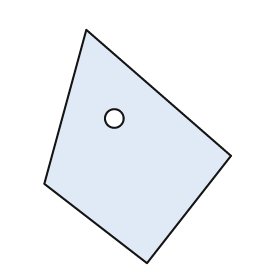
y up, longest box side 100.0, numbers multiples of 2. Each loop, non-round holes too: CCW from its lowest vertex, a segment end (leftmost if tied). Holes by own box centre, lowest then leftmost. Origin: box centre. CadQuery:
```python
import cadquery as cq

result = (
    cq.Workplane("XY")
    .moveTo(4.0, -50.0)
    .lineTo(40.0, -4.0)
    .lineTo(-22.0, 50.0)
    .lineTo(-40.0, -16.0)
    .close()
    .moveTo(-10.0, 12.0)
    .circle(4.0)
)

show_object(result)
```